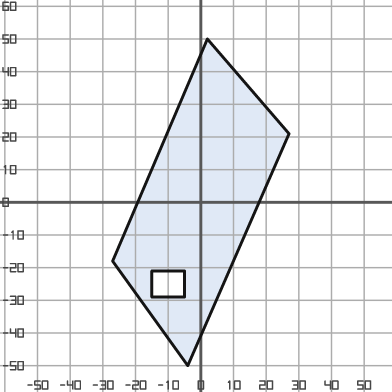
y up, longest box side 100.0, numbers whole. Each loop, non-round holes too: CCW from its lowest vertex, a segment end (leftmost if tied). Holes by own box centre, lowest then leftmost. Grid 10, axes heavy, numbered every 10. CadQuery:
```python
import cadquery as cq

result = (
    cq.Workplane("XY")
    .moveTo(-4.0, -50.0)
    .lineTo(27.0, 21.0)
    .lineTo(2.0, 50.0)
    .lineTo(-27.0, -18.0)
    .close()
    .moveTo(-15.0, -29.0)
    .lineTo(-5.0, -29.0)
    .lineTo(-5.0, -21.0)
    .lineTo(-15.0, -21.0)
    .close()
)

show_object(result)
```